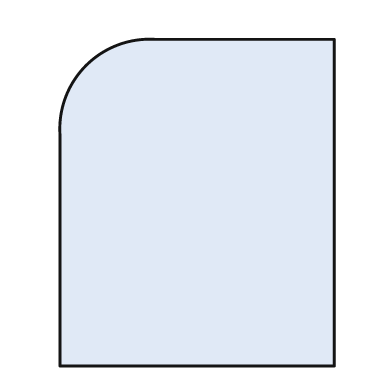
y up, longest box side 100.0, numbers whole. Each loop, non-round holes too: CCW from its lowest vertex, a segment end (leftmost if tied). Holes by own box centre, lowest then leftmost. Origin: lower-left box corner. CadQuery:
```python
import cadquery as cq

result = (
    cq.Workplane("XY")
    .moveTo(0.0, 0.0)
    .lineTo(84.0, 0.0)
    .lineTo(84.0, 100.0)
    .lineTo(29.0, 100.0)
    .threePointArc((8.0, 92.0), (0.0, 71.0))
    .close()
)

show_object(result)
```